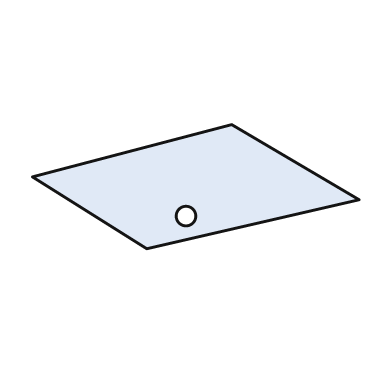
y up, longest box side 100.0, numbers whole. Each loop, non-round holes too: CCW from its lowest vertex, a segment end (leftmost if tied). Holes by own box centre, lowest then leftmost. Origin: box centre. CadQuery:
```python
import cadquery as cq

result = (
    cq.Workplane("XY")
    .moveTo(-15.0, -19.0)
    .lineTo(50.0, -4.0)
    .lineTo(11.0, 19.0)
    .lineTo(-50.0, 3.0)
    .close()
    .moveTo(-3.0, -9.0)
    .circle(3.0)
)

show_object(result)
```